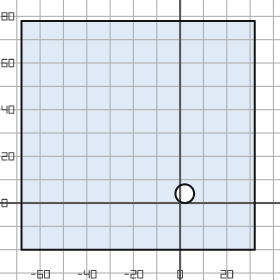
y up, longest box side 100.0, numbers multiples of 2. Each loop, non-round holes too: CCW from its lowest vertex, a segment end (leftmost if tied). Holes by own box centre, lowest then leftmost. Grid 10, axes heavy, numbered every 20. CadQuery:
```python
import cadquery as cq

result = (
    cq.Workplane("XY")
    .moveTo(-68.0, -20.0)
    .lineTo(32.0, -20.0)
    .lineTo(32.0, 78.0)
    .lineTo(-68.0, 78.0)
    .close()
    .moveTo(2.0, 4.0)
    .circle(4.0)
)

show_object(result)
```